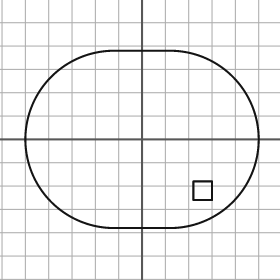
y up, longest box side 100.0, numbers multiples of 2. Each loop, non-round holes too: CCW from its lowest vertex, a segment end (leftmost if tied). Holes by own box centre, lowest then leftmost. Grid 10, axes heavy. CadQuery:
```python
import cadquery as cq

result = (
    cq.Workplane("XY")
    .moveTo(-12.0, -38.0)
    .lineTo(12.0, -38.0)
    .threePointArc((50.0, 0.0), (12.0, 38.0))
    .lineTo(-12.0, 38.0)
    .threePointArc((-50.0, 0.0), (-12.0, -38.0))
    .close()
    .moveTo(22.0, -26.0)
    .lineTo(30.0, -26.0)
    .lineTo(30.0, -18.0)
    .lineTo(22.0, -18.0)
    .close()
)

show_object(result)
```